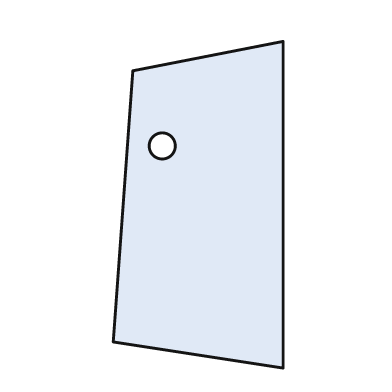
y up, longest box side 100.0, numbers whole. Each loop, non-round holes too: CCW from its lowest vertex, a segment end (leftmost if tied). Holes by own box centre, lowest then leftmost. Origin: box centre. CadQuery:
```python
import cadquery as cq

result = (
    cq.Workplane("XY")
    .moveTo(26.0, -50.0)
    .lineTo(26.0, 50.0)
    .lineTo(-20.0, 41.0)
    .lineTo(-26.0, -42.0)
    .close()
    .moveTo(-11.0, 18.0)
    .circle(4.0)
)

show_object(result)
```